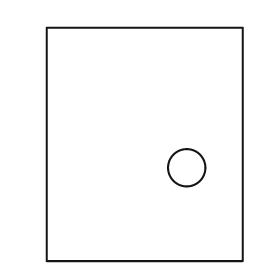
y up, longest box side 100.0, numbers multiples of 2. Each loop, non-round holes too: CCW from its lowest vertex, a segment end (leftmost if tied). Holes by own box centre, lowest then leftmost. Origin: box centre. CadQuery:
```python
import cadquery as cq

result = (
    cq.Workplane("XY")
    .moveTo(-42.0, -50.0)
    .lineTo(42.0, -50.0)
    .lineTo(42.0, 50.0)
    .lineTo(-42.0, 50.0)
    .close()
    .moveTo(18.0, -10.0)
    .circle(8.0)
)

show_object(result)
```